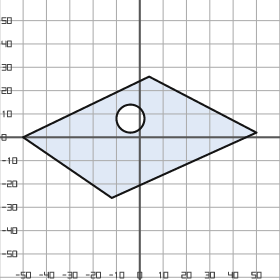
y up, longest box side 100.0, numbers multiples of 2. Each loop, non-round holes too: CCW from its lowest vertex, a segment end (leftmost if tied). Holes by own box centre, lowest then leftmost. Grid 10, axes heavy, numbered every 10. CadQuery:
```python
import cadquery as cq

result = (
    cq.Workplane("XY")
    .moveTo(-12.0, -26.0)
    .lineTo(50.0, 2.0)
    .lineTo(4.0, 26.0)
    .lineTo(-50.0, 0.0)
    .close()
    .moveTo(-4.0, 8.0)
    .circle(6.0)
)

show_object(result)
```